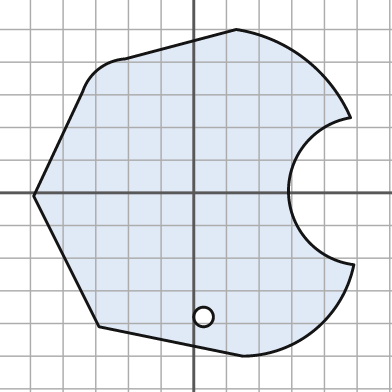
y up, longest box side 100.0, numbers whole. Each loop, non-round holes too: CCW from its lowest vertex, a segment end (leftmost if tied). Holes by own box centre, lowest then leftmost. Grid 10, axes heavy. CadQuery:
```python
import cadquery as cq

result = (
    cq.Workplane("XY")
    .moveTo(15.0, -50.0)
    .threePointArc((37.0, -42.0), (49.0, -22.0))
    .threePointArc((29.0, 0.0), (48.0, 23.0))
    .threePointArc((34.0, 41.0), (13.0, 50.0))
    .lineTo(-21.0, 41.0)
    .threePointArc((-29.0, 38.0), (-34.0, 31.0))
    .lineTo(-49.0, -1.0)
    .lineTo(-29.0, -41.0)
    .close()
    .moveTo(3.0, -38.0)
    .circle(3.0)
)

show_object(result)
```